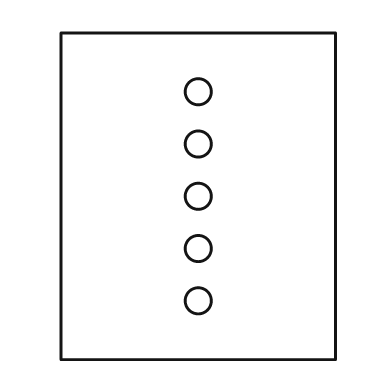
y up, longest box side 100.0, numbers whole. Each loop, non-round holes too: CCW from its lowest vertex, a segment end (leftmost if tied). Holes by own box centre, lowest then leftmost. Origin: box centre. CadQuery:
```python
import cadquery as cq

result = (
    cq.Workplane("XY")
    .moveTo(-42.0, -50.0)
    .lineTo(42.0, -50.0)
    .lineTo(42.0, 50.0)
    .lineTo(-42.0, 50.0)
    .close()
    .moveTo(0.0, -32.0)
    .circle(4.0)
    .moveTo(0.0, -16.0)
    .circle(4.0)
    .moveTo(0.0, 0.0)
    .circle(4.0)
    .moveTo(0.0, 16.0)
    .circle(4.0)
    .moveTo(0.0, 32.0)
    .circle(4.0)
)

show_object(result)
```